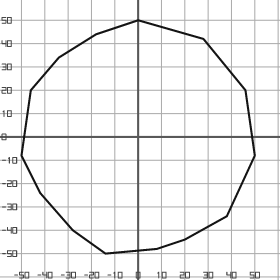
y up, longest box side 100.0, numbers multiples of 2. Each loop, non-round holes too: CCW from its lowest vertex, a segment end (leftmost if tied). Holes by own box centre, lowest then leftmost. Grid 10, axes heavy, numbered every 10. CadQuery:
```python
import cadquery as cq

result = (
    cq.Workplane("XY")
    .moveTo(-14.0, -50.0)
    .lineTo(8.0, -48.0)
    .lineTo(20.0, -44.0)
    .lineTo(38.0, -34.0)
    .lineTo(50.0, -8.0)
    .lineTo(46.0, 20.0)
    .lineTo(28.0, 42.0)
    .lineTo(0.0, 50.0)
    .lineTo(-18.0, 44.0)
    .lineTo(-34.0, 34.0)
    .lineTo(-46.0, 20.0)
    .lineTo(-50.0, -8.0)
    .lineTo(-42.0, -24.0)
    .lineTo(-28.0, -40.0)
    .close()
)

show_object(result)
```